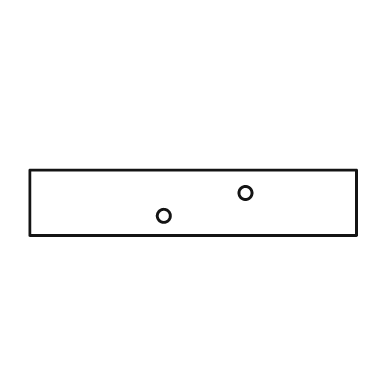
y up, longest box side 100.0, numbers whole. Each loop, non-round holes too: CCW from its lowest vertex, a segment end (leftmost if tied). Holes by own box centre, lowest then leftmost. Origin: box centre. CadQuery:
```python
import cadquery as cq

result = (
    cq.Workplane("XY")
    .moveTo(-50.0, -10.0)
    .lineTo(50.0, -10.0)
    .lineTo(50.0, 10.0)
    .lineTo(-50.0, 10.0)
    .close()
    .moveTo(-9.0, -4.0)
    .circle(2.0)
    .moveTo(16.0, 3.0)
    .circle(2.0)
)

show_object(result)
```